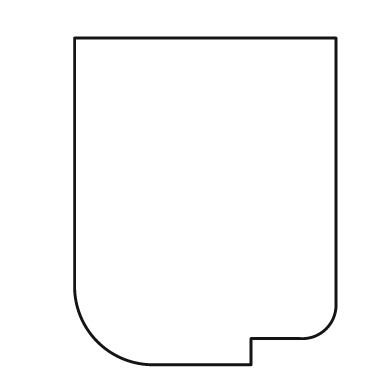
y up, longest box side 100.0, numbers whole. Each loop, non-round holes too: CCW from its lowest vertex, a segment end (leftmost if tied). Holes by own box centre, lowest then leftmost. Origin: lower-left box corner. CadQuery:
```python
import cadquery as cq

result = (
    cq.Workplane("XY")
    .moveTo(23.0, 0.0)
    .lineTo(54.0, 0.0)
    .lineTo(54.0, 8.0)
    .lineTo(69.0, 8.0)
    .threePointArc((77.0, 11.0), (80.0, 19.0))
    .lineTo(80.0, 100.0)
    .lineTo(0.0, 100.0)
    .lineTo(0.0, 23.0)
    .threePointArc((7.0, 7.0), (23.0, 0.0))
    .close()
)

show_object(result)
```